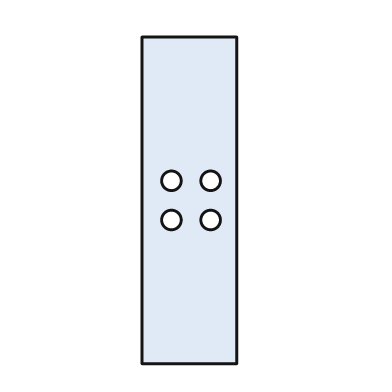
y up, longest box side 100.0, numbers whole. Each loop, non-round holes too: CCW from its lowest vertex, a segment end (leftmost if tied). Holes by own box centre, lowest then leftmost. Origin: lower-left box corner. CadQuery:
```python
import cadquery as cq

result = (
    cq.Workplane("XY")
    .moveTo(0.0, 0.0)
    .lineTo(29.0, 0.0)
    .lineTo(29.0, 100.0)
    .lineTo(0.0, 100.0)
    .close()
    .moveTo(9.0, 44.0)
    .circle(3.0)
    .moveTo(21.0, 44.0)
    .circle(3.0)
    .moveTo(9.0, 56.0)
    .circle(3.0)
    .moveTo(21.0, 56.0)
    .circle(3.0)
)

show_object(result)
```